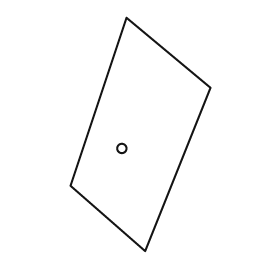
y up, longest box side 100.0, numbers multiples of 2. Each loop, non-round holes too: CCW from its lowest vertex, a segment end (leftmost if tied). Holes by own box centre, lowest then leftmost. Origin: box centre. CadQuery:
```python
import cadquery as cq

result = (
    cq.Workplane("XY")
    .moveTo(2.0, -50.0)
    .lineTo(30.0, 20.0)
    .lineTo(-6.0, 50.0)
    .lineTo(-30.0, -22.0)
    .close()
    .moveTo(-8.0, -6.0)
    .circle(2.0)
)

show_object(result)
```